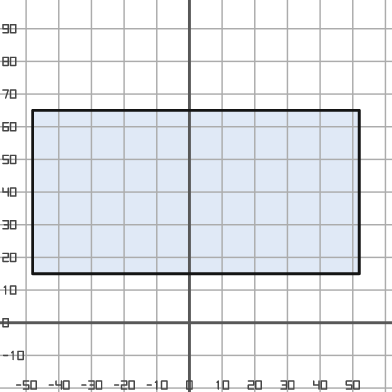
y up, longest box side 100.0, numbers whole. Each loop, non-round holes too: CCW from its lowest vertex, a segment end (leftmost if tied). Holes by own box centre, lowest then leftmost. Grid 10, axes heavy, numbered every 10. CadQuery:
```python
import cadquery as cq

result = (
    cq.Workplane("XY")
    .moveTo(-48.0, 15.0)
    .lineTo(52.0, 15.0)
    .lineTo(52.0, 65.0)
    .lineTo(-48.0, 65.0)
    .close()
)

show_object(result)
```